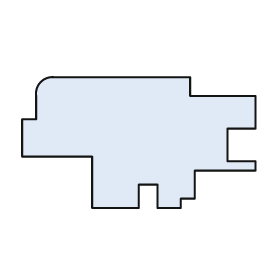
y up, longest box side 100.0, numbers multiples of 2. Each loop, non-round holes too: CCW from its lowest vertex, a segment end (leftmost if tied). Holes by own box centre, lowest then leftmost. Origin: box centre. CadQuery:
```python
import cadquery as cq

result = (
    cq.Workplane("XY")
    .moveTo(-20.0, -28.0)
    .lineTo(0.0, -28.0)
    .lineTo(0.0, -18.0)
    .lineTo(8.0, -18.0)
    .lineTo(8.0, -28.0)
    .lineTo(18.0, -28.0)
    .lineTo(18.0, -24.0)
    .lineTo(24.0, -24.0)
    .lineTo(24.0, -12.0)
    .lineTo(50.0, -12.0)
    .lineTo(50.0, -8.0)
    .lineTo(38.0, -8.0)
    .lineTo(38.0, 6.0)
    .lineTo(50.0, 6.0)
    .lineTo(50.0, 20.0)
    .lineTo(22.0, 20.0)
    .lineTo(22.0, 28.0)
    .lineTo(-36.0, 28.0)
    .threePointArc((-42.0, 26.0), (-44.0, 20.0))
    .lineTo(-44.0, 10.0)
    .lineTo(-50.0, 10.0)
    .lineTo(-50.0, -6.0)
    .lineTo(-20.0, -6.0)
    .close()
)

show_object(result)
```